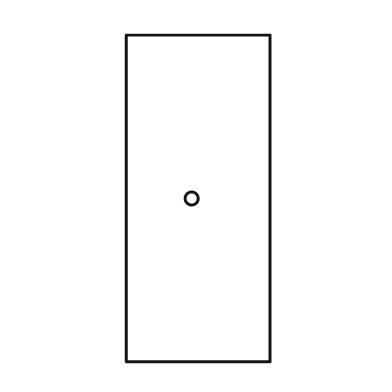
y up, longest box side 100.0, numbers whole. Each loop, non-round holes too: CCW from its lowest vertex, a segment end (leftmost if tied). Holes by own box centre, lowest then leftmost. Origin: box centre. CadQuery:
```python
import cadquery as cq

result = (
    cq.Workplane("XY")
    .moveTo(-22.0, -50.0)
    .lineTo(22.0, -50.0)
    .lineTo(22.0, 50.0)
    .lineTo(-22.0, 50.0)
    .close()
    .moveTo(-2.0, 0.0)
    .circle(2.0)
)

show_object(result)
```